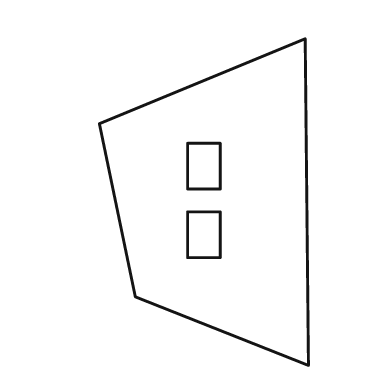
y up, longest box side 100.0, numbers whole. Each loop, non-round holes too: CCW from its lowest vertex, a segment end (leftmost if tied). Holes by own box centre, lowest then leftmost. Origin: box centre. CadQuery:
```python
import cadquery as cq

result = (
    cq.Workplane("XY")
    .moveTo(32.0, -50.0)
    .lineTo(31.0, 50.0)
    .lineTo(-32.0, 24.0)
    .lineTo(-21.0, -29.0)
    .close()
    .moveTo(-5.0, -17.0)
    .lineTo(5.0, -17.0)
    .lineTo(5.0, -3.0)
    .lineTo(-5.0, -3.0)
    .close()
    .moveTo(-5.0, 4.0)
    .lineTo(5.0, 4.0)
    .lineTo(5.0, 18.0)
    .lineTo(-5.0, 18.0)
    .close()
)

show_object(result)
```